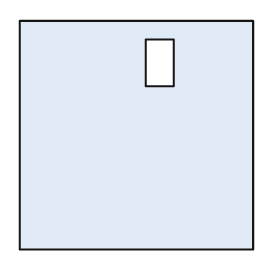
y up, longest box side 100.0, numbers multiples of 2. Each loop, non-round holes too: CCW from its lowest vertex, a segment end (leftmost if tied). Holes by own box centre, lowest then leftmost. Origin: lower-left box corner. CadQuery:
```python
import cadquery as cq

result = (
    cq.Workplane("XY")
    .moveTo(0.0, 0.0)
    .lineTo(100.0, 0.0)
    .lineTo(100.0, 98.0)
    .lineTo(0.0, 98.0)
    .close()
    .moveTo(54.0, 70.0)
    .lineTo(66.0, 70.0)
    .lineTo(66.0, 90.0)
    .lineTo(54.0, 90.0)
    .close()
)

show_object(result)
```